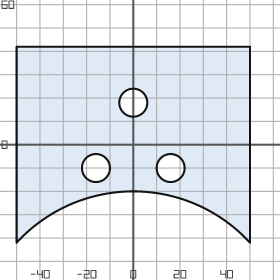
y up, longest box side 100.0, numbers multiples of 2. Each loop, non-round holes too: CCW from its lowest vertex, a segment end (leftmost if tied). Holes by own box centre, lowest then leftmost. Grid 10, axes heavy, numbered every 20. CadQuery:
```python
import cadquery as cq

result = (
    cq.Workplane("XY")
    .moveTo(-50.0, -42.0)
    .threePointArc((0.0, -20.0), (50.0, -42.0))
    .lineTo(50.0, 42.0)
    .lineTo(-50.0, 42.0)
    .close()
    .moveTo(-16.0, -10.0)
    .circle(6.0)
    .moveTo(16.0, -10.0)
    .circle(6.0)
    .moveTo(0.0, 18.0)
    .circle(6.0)
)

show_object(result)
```